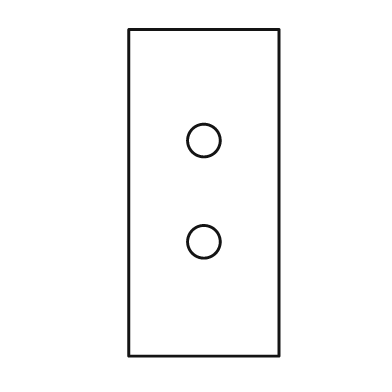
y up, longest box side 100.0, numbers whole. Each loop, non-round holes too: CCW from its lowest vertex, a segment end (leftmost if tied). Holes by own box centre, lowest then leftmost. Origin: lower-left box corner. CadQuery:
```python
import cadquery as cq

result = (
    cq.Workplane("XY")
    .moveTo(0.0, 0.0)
    .lineTo(46.0, 0.0)
    .lineTo(46.0, 100.0)
    .lineTo(0.0, 100.0)
    .close()
    .moveTo(23.0, 35.0)
    .circle(5.0)
    .moveTo(23.0, 66.0)
    .circle(5.0)
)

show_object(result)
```